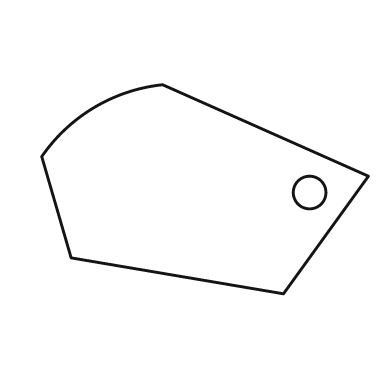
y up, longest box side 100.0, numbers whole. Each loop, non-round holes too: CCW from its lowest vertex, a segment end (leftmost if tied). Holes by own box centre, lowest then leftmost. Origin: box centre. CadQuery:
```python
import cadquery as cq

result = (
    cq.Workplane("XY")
    .moveTo(24.0, -32.0)
    .lineTo(50.0, 4.0)
    .lineTo(-13.0, 32.0)
    .threePointArc((-34.0, 25.0), (-50.0, 10.0))
    .lineTo(-41.0, -21.0)
    .close()
    .moveTo(32.0, -1.0)
    .circle(5.0)
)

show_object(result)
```